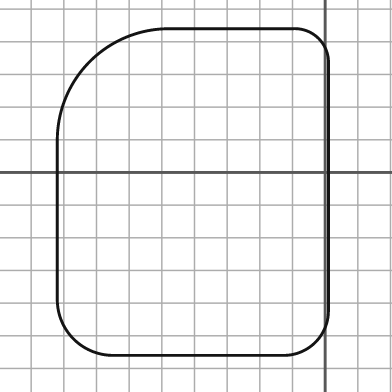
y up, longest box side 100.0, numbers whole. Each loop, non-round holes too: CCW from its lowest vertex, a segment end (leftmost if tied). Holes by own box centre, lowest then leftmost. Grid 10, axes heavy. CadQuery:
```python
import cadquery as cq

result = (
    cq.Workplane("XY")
    .moveTo(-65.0, -56.0)
    .lineTo(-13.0, -56.0)
    .threePointArc((-3.0, -52.0), (1.0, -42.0))
    .lineTo(1.0, 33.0)
    .threePointArc((-2.0, 41.0), (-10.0, 44.0))
    .lineTo(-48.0, 44.0)
    .threePointArc((-72.0, 34.0), (-82.0, 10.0))
    .lineTo(-82.0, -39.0)
    .threePointArc((-77.0, -51.0), (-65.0, -56.0))
    .close()
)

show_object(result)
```